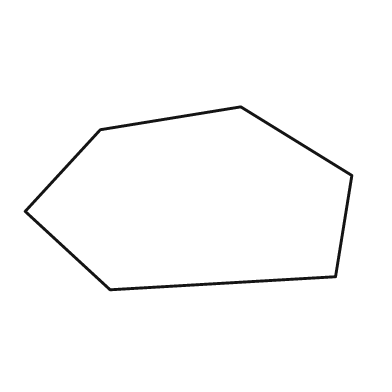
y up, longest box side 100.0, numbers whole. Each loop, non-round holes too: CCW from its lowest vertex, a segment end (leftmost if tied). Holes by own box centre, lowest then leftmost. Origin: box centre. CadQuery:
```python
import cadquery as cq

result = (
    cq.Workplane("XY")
    .moveTo(-24.0, -28.0)
    .lineTo(45.0, -24.0)
    .lineTo(50.0, 7.0)
    .lineTo(16.0, 28.0)
    .lineTo(-27.0, 21.0)
    .lineTo(-50.0, -4.0)
    .close()
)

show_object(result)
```